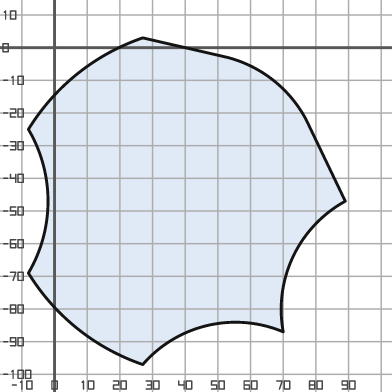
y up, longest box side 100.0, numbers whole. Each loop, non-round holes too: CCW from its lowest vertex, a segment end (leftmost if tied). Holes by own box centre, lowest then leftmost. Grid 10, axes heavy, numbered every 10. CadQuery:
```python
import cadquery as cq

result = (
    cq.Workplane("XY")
    .moveTo(27.0, -97.0)
    .threePointArc((47.0, -85.0), (70.0, -87.0))
    .threePointArc((73.0, -64.0), (89.0, -47.0))
    .lineTo(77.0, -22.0)
    .threePointArc((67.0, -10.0), (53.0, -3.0))
    .lineTo(27.0, 3.0)
    .threePointArc((7.0, -8.0), (-8.0, -25.0))
    .threePointArc((-2.0, -47.0), (-8.0, -69.0))
    .threePointArc((7.0, -86.0), (27.0, -97.0))
    .close()
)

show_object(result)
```